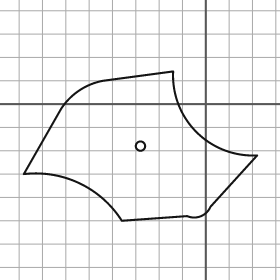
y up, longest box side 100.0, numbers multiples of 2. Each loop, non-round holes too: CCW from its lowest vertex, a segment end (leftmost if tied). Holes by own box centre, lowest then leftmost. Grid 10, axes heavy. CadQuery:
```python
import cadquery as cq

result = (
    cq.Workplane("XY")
    .moveTo(-36.0, -50.0)
    .lineTo(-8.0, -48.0)
    .threePointArc((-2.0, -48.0), (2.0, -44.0))
    .lineTo(22.0, -22.0)
    .threePointArc((-4.0, -12.0), (-14.0, 14.0))
    .lineTo(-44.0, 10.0)
    .threePointArc((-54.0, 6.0), (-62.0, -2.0))
    .lineTo(-78.0, -30.0)
    .threePointArc((-54.0, -34.0), (-36.0, -50.0))
    .close()
    .moveTo(-28.0, -18.0)
    .circle(2.0)
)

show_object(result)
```